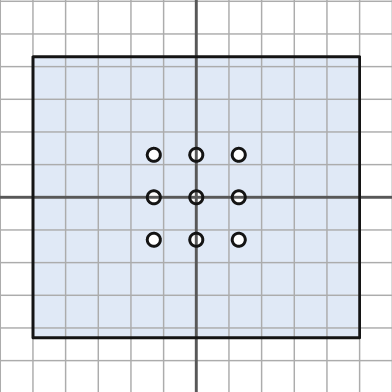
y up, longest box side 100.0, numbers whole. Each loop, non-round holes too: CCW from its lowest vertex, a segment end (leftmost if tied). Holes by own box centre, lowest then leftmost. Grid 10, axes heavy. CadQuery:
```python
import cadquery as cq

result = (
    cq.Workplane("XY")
    .moveTo(-50.0, -43.0)
    .lineTo(50.0, -43.0)
    .lineTo(50.0, 43.0)
    .lineTo(-50.0, 43.0)
    .close()
    .moveTo(-13.0, -13.0)
    .circle(2.0)
    .moveTo(0.0, -13.0)
    .circle(2.0)
    .moveTo(13.0, -13.0)
    .circle(2.0)
    .moveTo(-13.0, 0.0)
    .circle(2.0)
    .moveTo(0.0, 0.0)
    .circle(2.0)
    .moveTo(13.0, 0.0)
    .circle(2.0)
    .moveTo(-13.0, 13.0)
    .circle(2.0)
    .moveTo(0.0, 13.0)
    .circle(2.0)
    .moveTo(13.0, 13.0)
    .circle(2.0)
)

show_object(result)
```